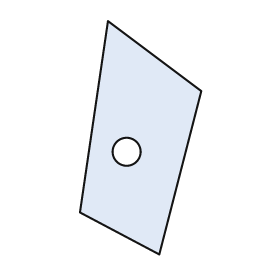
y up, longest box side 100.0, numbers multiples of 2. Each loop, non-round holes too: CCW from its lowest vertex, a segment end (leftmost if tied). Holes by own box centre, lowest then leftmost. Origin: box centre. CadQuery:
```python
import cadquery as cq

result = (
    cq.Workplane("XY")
    .moveTo(8.0, -50.0)
    .lineTo(26.0, 20.0)
    .lineTo(-14.0, 50.0)
    .lineTo(-26.0, -32.0)
    .close()
    .moveTo(-6.0, -6.0)
    .circle(6.0)
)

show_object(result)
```